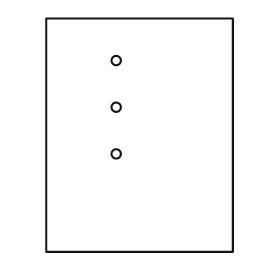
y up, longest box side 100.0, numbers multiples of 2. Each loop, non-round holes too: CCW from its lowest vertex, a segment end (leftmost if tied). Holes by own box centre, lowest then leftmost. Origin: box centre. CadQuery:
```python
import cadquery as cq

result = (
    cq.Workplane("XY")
    .moveTo(-40.0, -50.0)
    .lineTo(40.0, -50.0)
    .lineTo(40.0, 50.0)
    .lineTo(-40.0, 50.0)
    .close()
    .moveTo(-10.0, -8.0)
    .circle(2.0)
    .moveTo(-10.0, 12.0)
    .circle(2.0)
    .moveTo(-10.0, 32.0)
    .circle(2.0)
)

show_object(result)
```